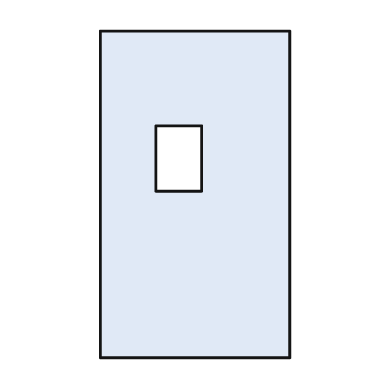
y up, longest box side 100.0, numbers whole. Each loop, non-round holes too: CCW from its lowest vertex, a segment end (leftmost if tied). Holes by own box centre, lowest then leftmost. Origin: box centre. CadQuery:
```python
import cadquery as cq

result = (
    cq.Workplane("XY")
    .moveTo(-29.0, -50.0)
    .lineTo(29.0, -50.0)
    .lineTo(29.0, 50.0)
    .lineTo(-29.0, 50.0)
    .close()
    .moveTo(-12.0, 1.0)
    .lineTo(2.0, 1.0)
    .lineTo(2.0, 21.0)
    .lineTo(-12.0, 21.0)
    .close()
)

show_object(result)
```